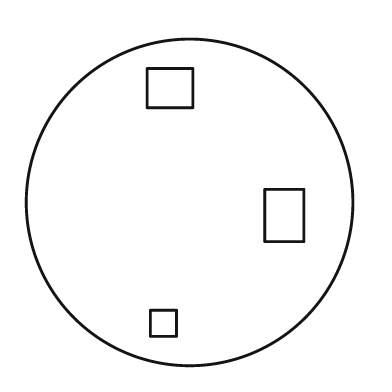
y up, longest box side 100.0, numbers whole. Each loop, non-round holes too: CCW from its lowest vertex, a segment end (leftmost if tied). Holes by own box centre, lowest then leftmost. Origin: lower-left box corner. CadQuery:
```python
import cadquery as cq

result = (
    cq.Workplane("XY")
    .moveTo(50.0, 50.0)
    .circle(50.0)
    .moveTo(38.0, 9.0)
    .lineTo(46.0, 9.0)
    .lineTo(46.0, 17.0)
    .lineTo(38.0, 17.0)
    .close()
    .moveTo(73.0, 38.0)
    .lineTo(85.0, 38.0)
    .lineTo(85.0, 54.0)
    .lineTo(73.0, 54.0)
    .close()
    .moveTo(37.0, 79.0)
    .lineTo(51.0, 79.0)
    .lineTo(51.0, 91.0)
    .lineTo(37.0, 91.0)
    .close()
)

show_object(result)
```